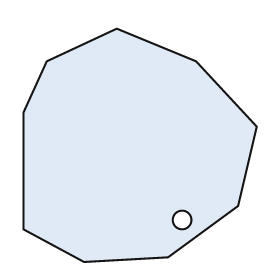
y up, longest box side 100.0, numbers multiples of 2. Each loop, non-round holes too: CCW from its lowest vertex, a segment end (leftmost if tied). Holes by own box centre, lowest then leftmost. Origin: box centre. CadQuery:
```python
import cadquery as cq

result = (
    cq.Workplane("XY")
    .moveTo(-24.0, -50.0)
    .lineTo(12.0, -48.0)
    .lineTo(42.0, -26.0)
    .lineTo(50.0, 8.0)
    .lineTo(24.0, 36.0)
    .lineTo(-10.0, 50.0)
    .lineTo(-40.0, 36.0)
    .lineTo(-50.0, 14.0)
    .lineTo(-50.0, -36.0)
    .close()
    .moveTo(18.0, -32.0)
    .circle(4.0)
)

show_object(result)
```